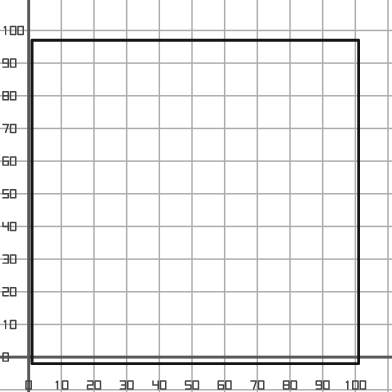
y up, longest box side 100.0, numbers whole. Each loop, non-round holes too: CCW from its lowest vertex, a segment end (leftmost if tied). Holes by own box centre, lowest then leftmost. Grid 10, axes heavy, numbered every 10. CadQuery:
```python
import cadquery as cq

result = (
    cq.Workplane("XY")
    .moveTo(1.0, -2.0)
    .lineTo(101.0, -2.0)
    .lineTo(101.0, 97.0)
    .lineTo(1.0, 97.0)
    .close()
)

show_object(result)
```